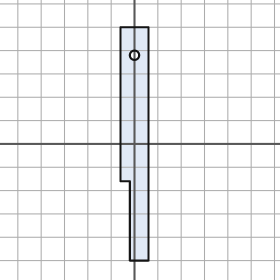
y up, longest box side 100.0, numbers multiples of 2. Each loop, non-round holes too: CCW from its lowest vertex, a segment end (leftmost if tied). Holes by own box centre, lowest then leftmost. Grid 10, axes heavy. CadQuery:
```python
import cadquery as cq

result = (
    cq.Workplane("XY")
    .moveTo(-2.0, -50.0)
    .lineTo(6.0, -50.0)
    .lineTo(6.0, 50.0)
    .lineTo(-6.0, 50.0)
    .lineTo(-6.0, -16.0)
    .lineTo(-2.0, -16.0)
    .close()
    .moveTo(0.0, 38.0)
    .circle(2.0)
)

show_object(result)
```